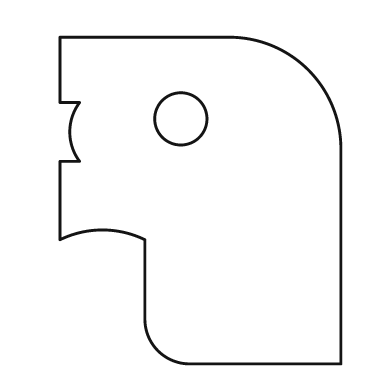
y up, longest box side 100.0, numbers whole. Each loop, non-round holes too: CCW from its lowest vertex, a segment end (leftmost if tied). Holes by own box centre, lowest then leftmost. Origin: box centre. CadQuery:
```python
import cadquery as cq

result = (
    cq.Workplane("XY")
    .moveTo(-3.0, -50.0)
    .lineTo(43.0, -50.0)
    .lineTo(43.0, 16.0)
    .threePointArc((33.0, 40.0), (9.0, 50.0))
    .lineTo(-43.0, 50.0)
    .lineTo(-43.0, 30.0)
    .lineTo(-37.0, 30.0)
    .threePointArc((-40.0, 21.0), (-37.0, 12.0))
    .lineTo(-43.0, 12.0)
    .lineTo(-43.0, -12.0)
    .threePointArc((-30.0, -9.0), (-17.0, -12.0))
    .lineTo(-17.0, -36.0)
    .threePointArc((-13.0, -46.0), (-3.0, -50.0))
    .close()
    .moveTo(-6.0, 25.0)
    .circle(8.0)
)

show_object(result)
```